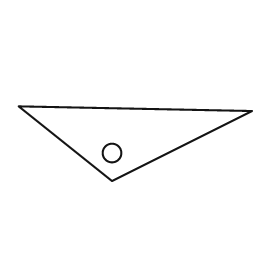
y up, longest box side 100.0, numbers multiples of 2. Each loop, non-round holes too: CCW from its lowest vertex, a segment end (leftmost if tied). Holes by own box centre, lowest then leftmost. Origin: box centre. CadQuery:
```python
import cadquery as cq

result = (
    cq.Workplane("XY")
    .moveTo(-10.0, -16.0)
    .lineTo(50.0, 14.0)
    .lineTo(-50.0, 16.0)
    .close()
    .moveTo(-10.0, -4.0)
    .circle(4.0)
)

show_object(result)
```